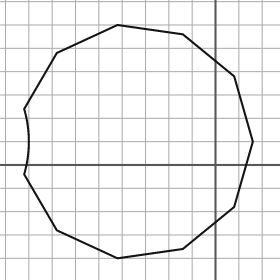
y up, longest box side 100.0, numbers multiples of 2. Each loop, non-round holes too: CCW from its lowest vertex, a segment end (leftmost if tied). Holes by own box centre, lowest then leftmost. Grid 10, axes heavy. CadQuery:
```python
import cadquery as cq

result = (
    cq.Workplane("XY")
    .moveTo(-42.0, -40.0)
    .lineTo(-14.0, -36.0)
    .lineTo(8.0, -18.0)
    .lineTo(16.0, 10.0)
    .lineTo(8.0, 38.0)
    .lineTo(-14.0, 56.0)
    .lineTo(-42.0, 60.0)
    .lineTo(-68.0, 48.0)
    .lineTo(-82.0, 24.0)
    .threePointArc((-80.0, 10.0), (-82.0, -4.0))
    .lineTo(-68.0, -28.0)
    .close()
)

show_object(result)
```